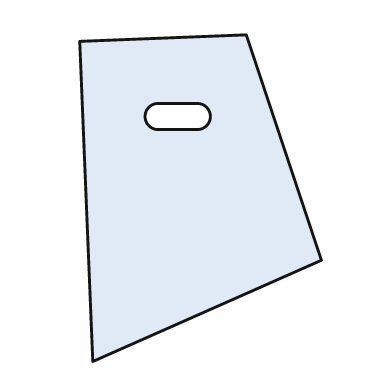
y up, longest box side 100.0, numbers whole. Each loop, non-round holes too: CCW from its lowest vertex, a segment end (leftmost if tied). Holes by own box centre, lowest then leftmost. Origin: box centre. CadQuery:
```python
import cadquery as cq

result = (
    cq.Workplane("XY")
    .moveTo(-33.0, -50.0)
    .lineTo(37.0, -19.0)
    .lineTo(14.0, 50.0)
    .lineTo(-37.0, 48.0)
    .close()
    .moveTo(-13.0, 21.0)
    .lineTo(-1.0, 21.0)
    .threePointArc((3.0, 25.0), (-1.0, 29.0))
    .lineTo(-13.0, 29.0)
    .threePointArc((-17.0, 25.0), (-13.0, 21.0))
    .close()
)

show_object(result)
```